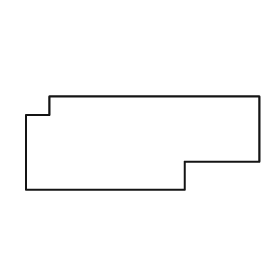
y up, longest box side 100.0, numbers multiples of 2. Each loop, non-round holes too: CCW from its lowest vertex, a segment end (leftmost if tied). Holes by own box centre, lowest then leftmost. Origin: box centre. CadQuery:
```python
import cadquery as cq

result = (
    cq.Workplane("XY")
    .moveTo(-50.0, -20.0)
    .lineTo(18.0, -20.0)
    .lineTo(18.0, -8.0)
    .lineTo(50.0, -8.0)
    .lineTo(50.0, 20.0)
    .lineTo(-40.0, 20.0)
    .lineTo(-40.0, 12.0)
    .lineTo(-50.0, 12.0)
    .close()
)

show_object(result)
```